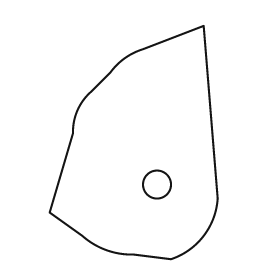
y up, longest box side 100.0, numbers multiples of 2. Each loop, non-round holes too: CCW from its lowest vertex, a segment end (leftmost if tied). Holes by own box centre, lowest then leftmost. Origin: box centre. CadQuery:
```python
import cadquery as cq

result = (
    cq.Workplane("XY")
    .moveTo(16.0, -50.0)
    .threePointArc((30.0, -40.0), (36.0, -24.0))
    .lineTo(30.0, 50.0)
    .lineTo(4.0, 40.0)
    .threePointArc((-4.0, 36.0), (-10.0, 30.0))
    .lineTo(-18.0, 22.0)
    .threePointArc((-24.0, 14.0), (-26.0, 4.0))
    .lineTo(-36.0, -30.0)
    .lineTo(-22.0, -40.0)
    .threePointArc((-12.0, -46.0), (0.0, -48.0))
    .close()
    .moveTo(10.0, -18.0)
    .circle(6.0)
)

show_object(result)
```